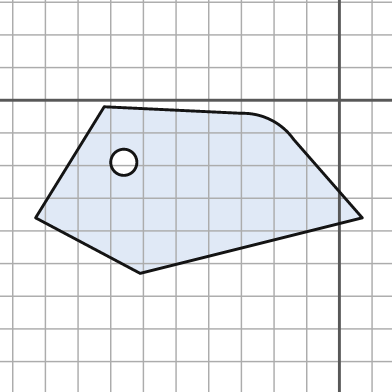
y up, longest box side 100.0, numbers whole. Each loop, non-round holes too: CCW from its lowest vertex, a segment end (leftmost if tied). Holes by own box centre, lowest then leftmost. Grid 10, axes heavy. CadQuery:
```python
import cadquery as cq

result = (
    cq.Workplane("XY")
    .moveTo(-61.0, -53.0)
    .lineTo(7.0, -36.0)
    .lineTo(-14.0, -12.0)
    .threePointArc((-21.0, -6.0), (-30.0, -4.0))
    .lineTo(-72.0, -2.0)
    .lineTo(-93.0, -36.0)
    .close()
    .moveTo(-66.0, -19.0)
    .circle(4.0)
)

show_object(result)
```